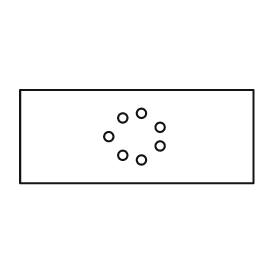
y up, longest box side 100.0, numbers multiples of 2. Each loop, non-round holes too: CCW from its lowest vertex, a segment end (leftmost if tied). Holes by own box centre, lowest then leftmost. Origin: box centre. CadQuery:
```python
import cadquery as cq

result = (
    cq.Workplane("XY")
    .moveTo(-50.0, -20.0)
    .lineTo(50.0, -20.0)
    .lineTo(50.0, 20.0)
    .lineTo(-50.0, 20.0)
    .close()
    .moveTo(2.0, -10.0)
    .circle(2.0)
    .moveTo(-6.0, -8.0)
    .circle(2.0)
    .moveTo(10.0, -4.0)
    .circle(2.0)
    .moveTo(-12.0, 0.0)
    .circle(2.0)
    .moveTo(10.0, 4.0)
    .circle(2.0)
    .moveTo(-6.0, 8.0)
    .circle(2.0)
    .moveTo(2.0, 10.0)
    .circle(2.0)
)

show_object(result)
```